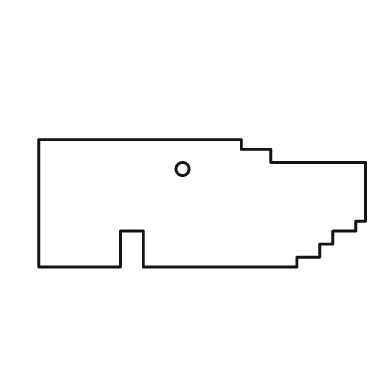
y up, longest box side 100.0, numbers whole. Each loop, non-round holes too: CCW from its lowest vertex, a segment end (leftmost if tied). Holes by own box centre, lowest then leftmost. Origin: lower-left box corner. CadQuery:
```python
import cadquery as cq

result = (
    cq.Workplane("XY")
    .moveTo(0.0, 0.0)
    .lineTo(25.0, 0.0)
    .lineTo(25.0, 11.0)
    .lineTo(32.0, 11.0)
    .lineTo(32.0, 0.0)
    .lineTo(79.0, 0.0)
    .lineTo(79.0, 3.0)
    .lineTo(86.0, 3.0)
    .lineTo(86.0, 7.0)
    .lineTo(90.0, 7.0)
    .lineTo(90.0, 11.0)
    .lineTo(97.0, 11.0)
    .lineTo(97.0, 14.0)
    .lineTo(100.0, 14.0)
    .lineTo(100.0, 32.0)
    .lineTo(71.0, 32.0)
    .lineTo(71.0, 36.0)
    .lineTo(62.0, 36.0)
    .lineTo(62.0, 39.0)
    .lineTo(0.0, 39.0)
    .close()
    .moveTo(44.0, 30.0)
    .circle(2.0)
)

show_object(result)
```